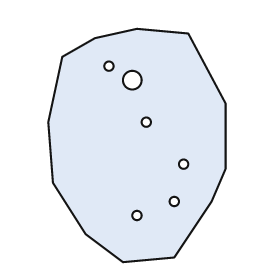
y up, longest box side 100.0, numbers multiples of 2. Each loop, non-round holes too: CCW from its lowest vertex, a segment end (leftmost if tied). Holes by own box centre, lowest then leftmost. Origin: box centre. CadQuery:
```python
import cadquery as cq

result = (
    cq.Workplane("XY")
    .moveTo(-6.0, -50.0)
    .lineTo(16.0, -48.0)
    .lineTo(32.0, -24.0)
    .lineTo(38.0, -10.0)
    .lineTo(38.0, 18.0)
    .lineTo(22.0, 48.0)
    .lineTo(0.0, 50.0)
    .lineTo(-18.0, 46.0)
    .lineTo(-32.0, 38.0)
    .lineTo(-38.0, 10.0)
    .lineTo(-36.0, -16.0)
    .lineTo(-22.0, -38.0)
    .close()
    .moveTo(0.0, -30.0)
    .circle(2.0)
    .moveTo(16.0, -24.0)
    .circle(2.0)
    .moveTo(20.0, -8.0)
    .circle(2.0)
    .moveTo(4.0, 10.0)
    .circle(2.0)
    .moveTo(-2.0, 28.0)
    .circle(4.0)
    .moveTo(-12.0, 34.0)
    .circle(2.0)
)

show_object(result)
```